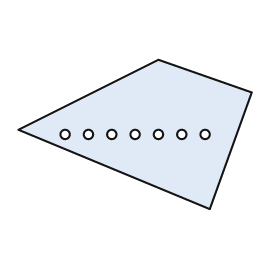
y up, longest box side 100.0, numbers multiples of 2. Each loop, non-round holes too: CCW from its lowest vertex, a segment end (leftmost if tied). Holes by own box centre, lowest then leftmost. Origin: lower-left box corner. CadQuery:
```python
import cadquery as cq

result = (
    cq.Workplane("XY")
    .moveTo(82.0, 0.0)
    .lineTo(100.0, 50.0)
    .lineTo(60.0, 64.0)
    .lineTo(0.0, 34.0)
    .close()
    .moveTo(20.0, 32.0)
    .circle(2.0)
    .moveTo(30.0, 32.0)
    .circle(2.0)
    .moveTo(40.0, 32.0)
    .circle(2.0)
    .moveTo(50.0, 32.0)
    .circle(2.0)
    .moveTo(60.0, 32.0)
    .circle(2.0)
    .moveTo(70.0, 32.0)
    .circle(2.0)
    .moveTo(80.0, 32.0)
    .circle(2.0)
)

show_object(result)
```